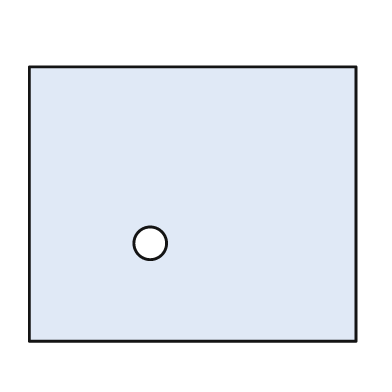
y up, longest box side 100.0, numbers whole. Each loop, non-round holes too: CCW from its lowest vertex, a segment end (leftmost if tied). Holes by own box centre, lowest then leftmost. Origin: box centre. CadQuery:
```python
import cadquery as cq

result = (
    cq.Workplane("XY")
    .moveTo(-50.0, -42.0)
    .lineTo(50.0, -42.0)
    .lineTo(50.0, 42.0)
    .lineTo(-50.0, 42.0)
    .close()
    .moveTo(-13.0, -12.0)
    .circle(5.0)
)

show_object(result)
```